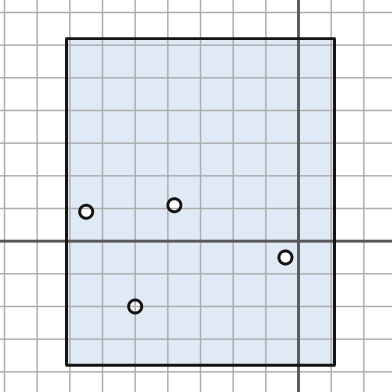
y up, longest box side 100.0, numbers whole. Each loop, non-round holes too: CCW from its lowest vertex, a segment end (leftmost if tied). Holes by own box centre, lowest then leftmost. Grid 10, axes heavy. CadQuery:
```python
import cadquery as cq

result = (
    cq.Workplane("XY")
    .moveTo(-71.0, -38.0)
    .lineTo(11.0, -38.0)
    .lineTo(11.0, 62.0)
    .lineTo(-71.0, 62.0)
    .close()
    .moveTo(-50.0, -20.0)
    .circle(2.0)
    .moveTo(-4.0, -5.0)
    .circle(2.0)
    .moveTo(-65.0, 9.0)
    .circle(2.0)
    .moveTo(-38.0, 11.0)
    .circle(2.0)
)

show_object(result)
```